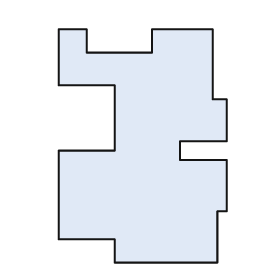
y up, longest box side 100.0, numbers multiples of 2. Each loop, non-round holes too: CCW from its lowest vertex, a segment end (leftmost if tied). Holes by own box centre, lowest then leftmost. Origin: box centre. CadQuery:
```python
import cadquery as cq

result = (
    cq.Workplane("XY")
    .moveTo(-12.0, -50.0)
    .lineTo(32.0, -50.0)
    .lineTo(32.0, -28.0)
    .lineTo(36.0, -28.0)
    .lineTo(36.0, -6.0)
    .lineTo(16.0, -6.0)
    .lineTo(16.0, 2.0)
    .lineTo(36.0, 2.0)
    .lineTo(36.0, 20.0)
    .lineTo(30.0, 20.0)
    .lineTo(30.0, 50.0)
    .lineTo(4.0, 50.0)
    .lineTo(4.0, 40.0)
    .lineTo(-24.0, 40.0)
    .lineTo(-24.0, 50.0)
    .lineTo(-36.0, 50.0)
    .lineTo(-36.0, 26.0)
    .lineTo(-12.0, 26.0)
    .lineTo(-12.0, -2.0)
    .lineTo(-36.0, -2.0)
    .lineTo(-36.0, -40.0)
    .lineTo(-12.0, -40.0)
    .close()
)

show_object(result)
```